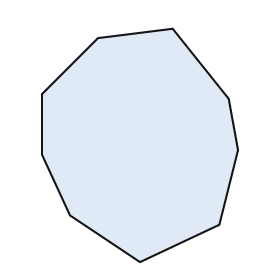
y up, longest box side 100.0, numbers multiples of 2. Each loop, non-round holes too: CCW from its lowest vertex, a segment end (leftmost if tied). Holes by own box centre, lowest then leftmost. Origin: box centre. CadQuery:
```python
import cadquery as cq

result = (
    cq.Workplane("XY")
    .moveTo(0.0, -50.0)
    .lineTo(34.0, -34.0)
    .lineTo(42.0, -2.0)
    .lineTo(38.0, 20.0)
    .lineTo(14.0, 50.0)
    .lineTo(-18.0, 46.0)
    .lineTo(-42.0, 22.0)
    .lineTo(-42.0, -4.0)
    .lineTo(-30.0, -30.0)
    .close()
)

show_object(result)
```